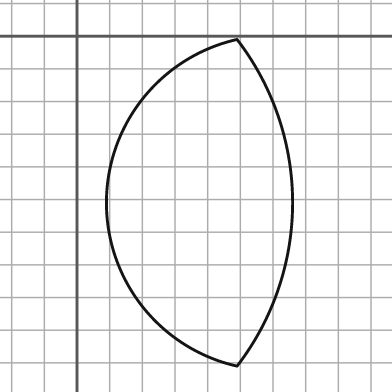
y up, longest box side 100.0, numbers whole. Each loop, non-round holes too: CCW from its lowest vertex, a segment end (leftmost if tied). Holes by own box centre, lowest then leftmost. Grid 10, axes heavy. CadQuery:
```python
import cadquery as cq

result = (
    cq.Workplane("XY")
    .moveTo(49.0, -101.0)
    .threePointArc((66.0, -51.0), (49.0, -1.0))
    .threePointArc((9.0, -51.0), (49.0, -101.0))
    .close()
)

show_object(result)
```